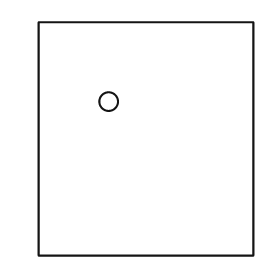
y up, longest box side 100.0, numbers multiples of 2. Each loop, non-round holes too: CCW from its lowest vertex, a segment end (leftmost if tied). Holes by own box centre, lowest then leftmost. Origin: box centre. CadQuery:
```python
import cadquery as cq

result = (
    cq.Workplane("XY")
    .moveTo(-46.0, -50.0)
    .lineTo(46.0, -50.0)
    .lineTo(46.0, 50.0)
    .lineTo(-46.0, 50.0)
    .close()
    .moveTo(-16.0, 16.0)
    .circle(4.0)
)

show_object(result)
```